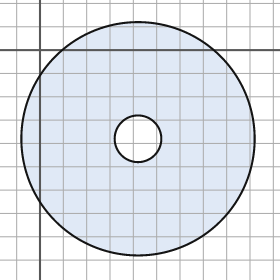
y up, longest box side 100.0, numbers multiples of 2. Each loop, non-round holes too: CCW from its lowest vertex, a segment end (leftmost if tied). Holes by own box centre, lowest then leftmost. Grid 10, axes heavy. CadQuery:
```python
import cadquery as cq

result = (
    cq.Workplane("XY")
    .moveTo(42.0, -38.0)
    .circle(50.0)
    .moveTo(42.0, -38.0)
    .circle(10.0)
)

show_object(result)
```